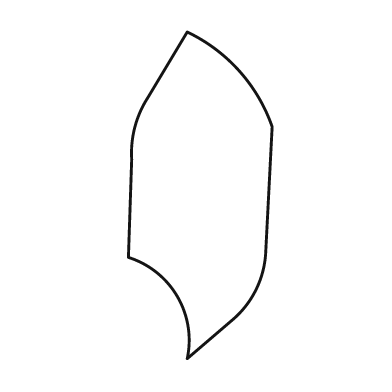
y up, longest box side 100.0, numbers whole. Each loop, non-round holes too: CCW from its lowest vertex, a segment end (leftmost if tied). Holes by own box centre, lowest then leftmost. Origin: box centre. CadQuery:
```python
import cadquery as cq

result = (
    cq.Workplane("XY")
    .moveTo(-4.0, -50.0)
    .lineTo(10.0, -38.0)
    .threePointArc((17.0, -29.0), (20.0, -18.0))
    .lineTo(22.0, 21.0)
    .threePointArc((12.0, 38.0), (-4.0, 50.0))
    .lineTo(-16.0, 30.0)
    .threePointArc((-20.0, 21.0), (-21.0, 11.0))
    .lineTo(-22.0, -19.0)
    .threePointArc((-7.0, -31.0), (-4.0, -50.0))
    .close()
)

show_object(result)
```